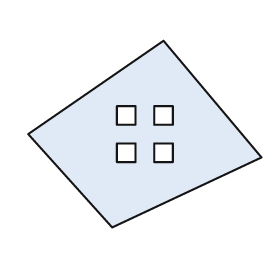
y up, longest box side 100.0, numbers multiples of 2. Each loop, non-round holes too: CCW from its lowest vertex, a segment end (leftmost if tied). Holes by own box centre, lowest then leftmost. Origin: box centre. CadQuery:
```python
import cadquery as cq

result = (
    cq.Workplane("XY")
    .moveTo(-14.0, -40.0)
    .lineTo(50.0, -10.0)
    .lineTo(8.0, 40.0)
    .lineTo(-50.0, 0.0)
    .close()
    .moveTo(-12.0, -12.0)
    .lineTo(-4.0, -12.0)
    .lineTo(-4.0, -4.0)
    .lineTo(-12.0, -4.0)
    .close()
    .moveTo(4.0, -12.0)
    .lineTo(12.0, -12.0)
    .lineTo(12.0, -4.0)
    .lineTo(4.0, -4.0)
    .close()
    .moveTo(-12.0, 4.0)
    .lineTo(-4.0, 4.0)
    .lineTo(-4.0, 12.0)
    .lineTo(-12.0, 12.0)
    .close()
    .moveTo(4.0, 4.0)
    .lineTo(12.0, 4.0)
    .lineTo(12.0, 12.0)
    .lineTo(4.0, 12.0)
    .close()
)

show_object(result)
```